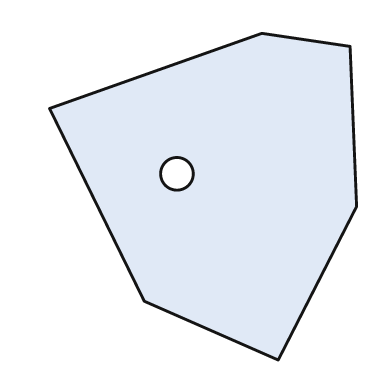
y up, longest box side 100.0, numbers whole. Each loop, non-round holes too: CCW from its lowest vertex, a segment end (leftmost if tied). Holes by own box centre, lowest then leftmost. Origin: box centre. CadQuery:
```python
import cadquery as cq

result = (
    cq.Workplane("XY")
    .moveTo(23.0, -50.0)
    .lineTo(47.0, -3.0)
    .lineTo(45.0, 46.0)
    .lineTo(18.0, 50.0)
    .lineTo(-47.0, 27.0)
    .lineTo(-18.0, -32.0)
    .close()
    .moveTo(-8.0, 7.0)
    .circle(5.0)
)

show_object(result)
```